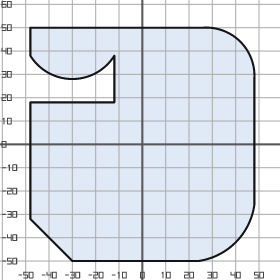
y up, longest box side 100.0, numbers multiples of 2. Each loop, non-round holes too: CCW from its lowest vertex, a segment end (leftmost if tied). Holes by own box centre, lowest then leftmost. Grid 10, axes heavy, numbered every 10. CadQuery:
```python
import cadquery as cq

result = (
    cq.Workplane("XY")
    .moveTo(-30.0, -50.0)
    .lineTo(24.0, -50.0)
    .threePointArc((40.0, -42.0), (48.0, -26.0))
    .lineTo(48.0, 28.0)
    .threePointArc((42.0, 44.0), (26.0, 50.0))
    .lineTo(-48.0, 50.0)
    .lineTo(-48.0, 38.0)
    .threePointArc((-30.0, 28.0), (-12.0, 38.0))
    .lineTo(-12.0, 18.0)
    .lineTo(-48.0, 18.0)
    .lineTo(-48.0, -32.0)
    .close()
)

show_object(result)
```